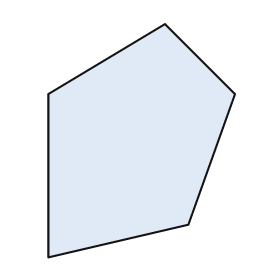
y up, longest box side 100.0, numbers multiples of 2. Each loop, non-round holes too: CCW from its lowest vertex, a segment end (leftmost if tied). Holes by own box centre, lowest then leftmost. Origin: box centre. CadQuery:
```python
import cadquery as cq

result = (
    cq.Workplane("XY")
    .moveTo(-40.0, -50.0)
    .lineTo(20.0, -36.0)
    .lineTo(40.0, 20.0)
    .lineTo(10.0, 50.0)
    .lineTo(-40.0, 20.0)
    .close()
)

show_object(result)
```